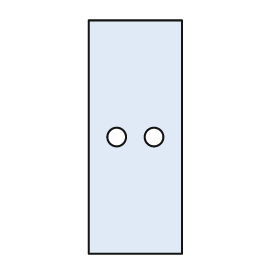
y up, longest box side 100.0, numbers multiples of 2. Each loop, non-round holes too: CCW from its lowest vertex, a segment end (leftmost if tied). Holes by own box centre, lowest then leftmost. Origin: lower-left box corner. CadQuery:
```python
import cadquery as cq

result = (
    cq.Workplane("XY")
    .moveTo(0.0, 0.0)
    .lineTo(40.0, 0.0)
    .lineTo(40.0, 100.0)
    .lineTo(0.0, 100.0)
    .close()
    .moveTo(12.0, 50.0)
    .circle(4.0)
    .moveTo(28.0, 50.0)
    .circle(4.0)
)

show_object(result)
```